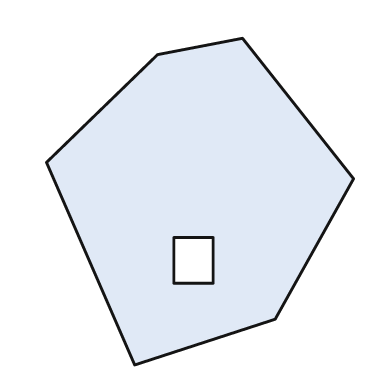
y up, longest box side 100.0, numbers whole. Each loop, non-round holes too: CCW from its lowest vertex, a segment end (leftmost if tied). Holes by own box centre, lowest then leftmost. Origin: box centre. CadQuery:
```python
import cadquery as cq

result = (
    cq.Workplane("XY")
    .moveTo(-20.0, -50.0)
    .lineTo(23.0, -36.0)
    .lineTo(47.0, 7.0)
    .lineTo(13.0, 50.0)
    .lineTo(-13.0, 45.0)
    .lineTo(-47.0, 12.0)
    .close()
    .moveTo(-8.0, -25.0)
    .lineTo(4.0, -25.0)
    .lineTo(4.0, -11.0)
    .lineTo(-8.0, -11.0)
    .close()
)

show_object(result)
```